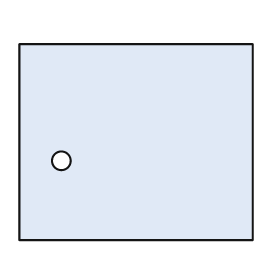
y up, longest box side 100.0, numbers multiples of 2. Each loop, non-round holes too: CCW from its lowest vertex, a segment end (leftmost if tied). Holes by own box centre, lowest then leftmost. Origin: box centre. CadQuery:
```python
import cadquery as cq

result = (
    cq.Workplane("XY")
    .moveTo(-50.0, -42.0)
    .lineTo(50.0, -42.0)
    .lineTo(50.0, 42.0)
    .lineTo(-50.0, 42.0)
    .close()
    .moveTo(-32.0, -8.0)
    .circle(4.0)
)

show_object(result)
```